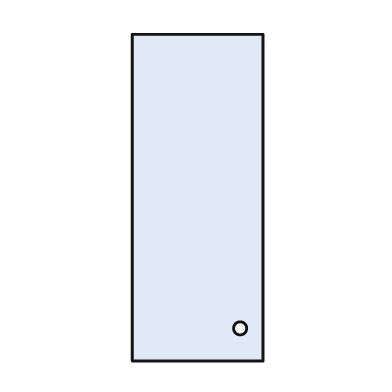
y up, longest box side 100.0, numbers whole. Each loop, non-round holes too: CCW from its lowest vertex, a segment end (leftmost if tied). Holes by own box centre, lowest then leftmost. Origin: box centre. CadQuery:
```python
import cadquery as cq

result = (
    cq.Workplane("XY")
    .moveTo(-20.0, -50.0)
    .lineTo(20.0, -50.0)
    .lineTo(20.0, 50.0)
    .lineTo(-20.0, 50.0)
    .close()
    .moveTo(13.0, -40.0)
    .circle(2.0)
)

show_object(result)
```